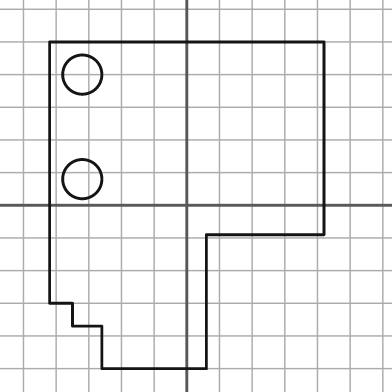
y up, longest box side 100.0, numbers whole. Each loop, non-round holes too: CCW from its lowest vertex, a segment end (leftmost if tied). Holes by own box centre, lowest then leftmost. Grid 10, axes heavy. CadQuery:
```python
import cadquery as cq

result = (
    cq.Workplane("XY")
    .moveTo(-26.0, -50.0)
    .lineTo(6.0, -50.0)
    .lineTo(6.0, -9.0)
    .lineTo(42.0, -9.0)
    .lineTo(42.0, 50.0)
    .lineTo(-42.0, 50.0)
    .lineTo(-42.0, -30.0)
    .lineTo(-35.0, -30.0)
    .lineTo(-35.0, -37.0)
    .lineTo(-26.0, -37.0)
    .close()
    .moveTo(-32.0, 8.0)
    .circle(6.0)
    .moveTo(-32.0, 40.0)
    .circle(6.0)
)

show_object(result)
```